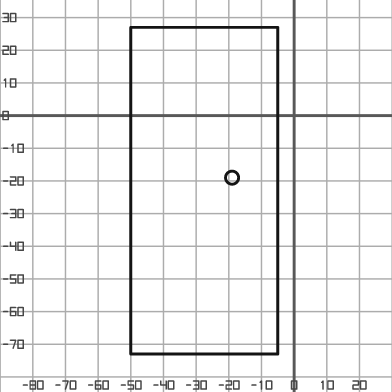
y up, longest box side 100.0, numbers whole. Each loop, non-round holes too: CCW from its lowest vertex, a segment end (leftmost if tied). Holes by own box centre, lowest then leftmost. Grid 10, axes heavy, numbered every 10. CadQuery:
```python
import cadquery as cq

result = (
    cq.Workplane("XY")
    .moveTo(-50.0, -73.0)
    .lineTo(-5.0, -73.0)
    .lineTo(-5.0, 27.0)
    .lineTo(-50.0, 27.0)
    .close()
    .moveTo(-19.0, -19.0)
    .circle(2.0)
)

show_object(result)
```